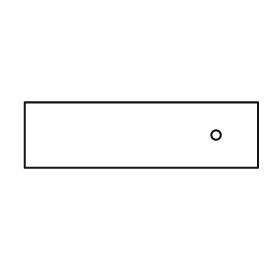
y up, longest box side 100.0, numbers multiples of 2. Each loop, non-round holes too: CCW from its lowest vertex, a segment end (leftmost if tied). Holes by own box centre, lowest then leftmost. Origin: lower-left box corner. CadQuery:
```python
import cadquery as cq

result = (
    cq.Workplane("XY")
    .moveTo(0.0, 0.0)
    .lineTo(100.0, 0.0)
    .lineTo(100.0, 28.0)
    .lineTo(0.0, 28.0)
    .close()
    .moveTo(82.0, 14.0)
    .circle(2.0)
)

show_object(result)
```